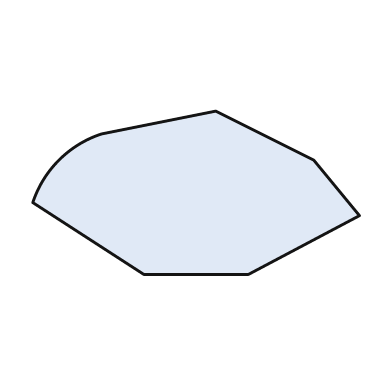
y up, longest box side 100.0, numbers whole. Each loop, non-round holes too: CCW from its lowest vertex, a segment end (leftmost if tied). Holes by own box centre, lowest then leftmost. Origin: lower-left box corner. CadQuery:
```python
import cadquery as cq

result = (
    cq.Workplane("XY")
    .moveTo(34.0, 0.0)
    .lineTo(66.0, 0.0)
    .lineTo(100.0, 18.0)
    .lineTo(86.0, 35.0)
    .lineTo(56.0, 50.0)
    .lineTo(21.0, 43.0)
    .threePointArc((8.0, 35.0), (0.0, 22.0))
    .close()
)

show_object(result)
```